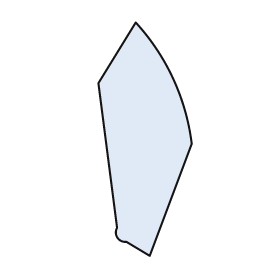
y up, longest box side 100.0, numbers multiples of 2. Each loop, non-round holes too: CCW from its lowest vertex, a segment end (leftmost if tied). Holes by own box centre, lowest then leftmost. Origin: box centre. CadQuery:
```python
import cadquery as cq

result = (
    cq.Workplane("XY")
    .moveTo(2.0, -50.0)
    .lineTo(20.0, -2.0)
    .threePointArc((12.0, 26.0), (-4.0, 50.0))
    .lineTo(-20.0, 24.0)
    .lineTo(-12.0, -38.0)
    .threePointArc((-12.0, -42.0), (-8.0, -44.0))
    .close()
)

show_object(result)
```